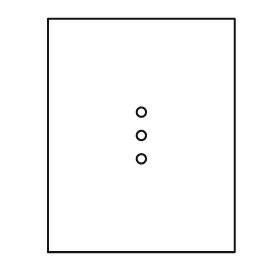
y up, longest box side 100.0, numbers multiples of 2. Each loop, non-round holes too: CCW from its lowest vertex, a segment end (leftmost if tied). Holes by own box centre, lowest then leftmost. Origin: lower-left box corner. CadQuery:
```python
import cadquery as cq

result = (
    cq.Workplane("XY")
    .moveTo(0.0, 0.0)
    .lineTo(80.0, 0.0)
    .lineTo(80.0, 100.0)
    .lineTo(0.0, 100.0)
    .close()
    .moveTo(40.0, 40.0)
    .circle(2.0)
    .moveTo(40.0, 50.0)
    .circle(2.0)
    .moveTo(40.0, 60.0)
    .circle(2.0)
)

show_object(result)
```